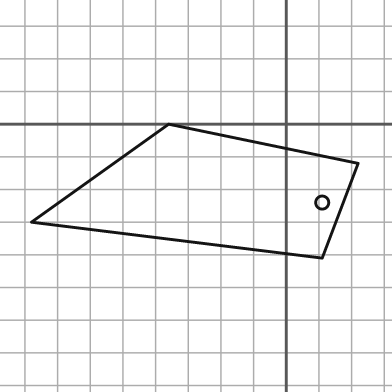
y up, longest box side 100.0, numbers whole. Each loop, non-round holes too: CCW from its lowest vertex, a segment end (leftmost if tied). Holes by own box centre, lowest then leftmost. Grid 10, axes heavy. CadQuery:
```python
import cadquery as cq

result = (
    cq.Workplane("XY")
    .moveTo(11.0, -41.0)
    .lineTo(22.0, -12.0)
    .lineTo(-36.0, 0.0)
    .lineTo(-78.0, -30.0)
    .close()
    .moveTo(11.0, -24.0)
    .circle(2.0)
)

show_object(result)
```